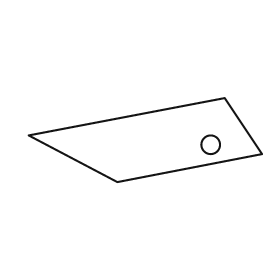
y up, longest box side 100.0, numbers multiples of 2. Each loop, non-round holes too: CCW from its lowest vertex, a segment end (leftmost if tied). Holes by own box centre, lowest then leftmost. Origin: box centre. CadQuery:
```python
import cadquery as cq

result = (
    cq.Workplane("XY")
    .moveTo(-12.0, -18.0)
    .lineTo(50.0, -6.0)
    .lineTo(34.0, 18.0)
    .lineTo(-50.0, 2.0)
    .close()
    .moveTo(28.0, -2.0)
    .circle(4.0)
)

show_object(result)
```